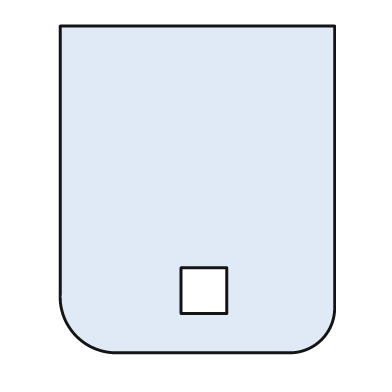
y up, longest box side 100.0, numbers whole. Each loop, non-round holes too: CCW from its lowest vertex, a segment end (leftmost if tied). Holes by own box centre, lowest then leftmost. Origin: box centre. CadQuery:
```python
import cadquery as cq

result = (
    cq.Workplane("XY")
    .moveTo(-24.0, -50.0)
    .lineTo(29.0, -50.0)
    .threePointArc((38.0, -46.0), (42.0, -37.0))
    .lineTo(42.0, 50.0)
    .lineTo(-42.0, 50.0)
    .lineTo(-42.0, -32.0)
    .threePointArc((-37.0, -45.0), (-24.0, -50.0))
    .close()
    .moveTo(-5.0, -38.0)
    .lineTo(9.0, -38.0)
    .lineTo(9.0, -24.0)
    .lineTo(-5.0, -24.0)
    .close()
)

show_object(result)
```